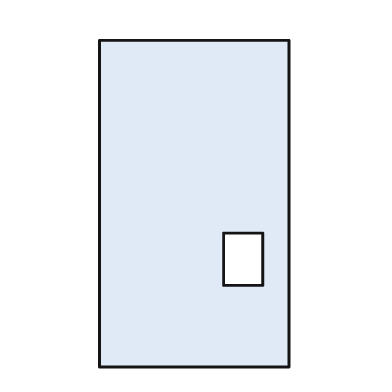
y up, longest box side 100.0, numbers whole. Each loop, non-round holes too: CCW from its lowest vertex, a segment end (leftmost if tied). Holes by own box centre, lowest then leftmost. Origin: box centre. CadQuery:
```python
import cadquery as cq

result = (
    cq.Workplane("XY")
    .moveTo(-29.0, -50.0)
    .lineTo(29.0, -50.0)
    .lineTo(29.0, 50.0)
    .lineTo(-29.0, 50.0)
    .close()
    .moveTo(9.0, -25.0)
    .lineTo(21.0, -25.0)
    .lineTo(21.0, -9.0)
    .lineTo(9.0, -9.0)
    .close()
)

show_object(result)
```